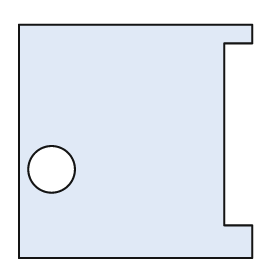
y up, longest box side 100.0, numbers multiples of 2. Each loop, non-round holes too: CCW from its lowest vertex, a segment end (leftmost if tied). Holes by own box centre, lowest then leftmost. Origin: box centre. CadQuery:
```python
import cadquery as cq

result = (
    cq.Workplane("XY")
    .moveTo(-50.0, -50.0)
    .lineTo(50.0, -50.0)
    .lineTo(50.0, -36.0)
    .lineTo(38.0, -36.0)
    .lineTo(38.0, 42.0)
    .lineTo(50.0, 42.0)
    .lineTo(50.0, 50.0)
    .lineTo(-50.0, 50.0)
    .close()
    .moveTo(-36.0, -12.0)
    .circle(10.0)
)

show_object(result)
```